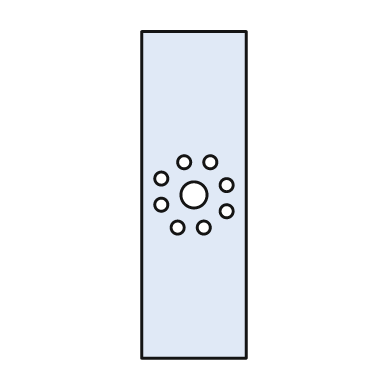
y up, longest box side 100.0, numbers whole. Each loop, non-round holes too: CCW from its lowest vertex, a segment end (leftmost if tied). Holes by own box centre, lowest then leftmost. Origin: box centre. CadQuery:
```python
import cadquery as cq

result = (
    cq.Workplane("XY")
    .moveTo(-16.0, -50.0)
    .lineTo(16.0, -50.0)
    .lineTo(16.0, 50.0)
    .lineTo(-16.0, 50.0)
    .close()
    .moveTo(-5.0, -10.0)
    .circle(2.0)
    .moveTo(3.0, -10.0)
    .circle(2.0)
    .moveTo(10.0, -5.0)
    .circle(2.0)
    .moveTo(-10.0, -3.0)
    .circle(2.0)
    .moveTo(0.0, 0.0)
    .circle(4.0)
    .moveTo(10.0, 3.0)
    .circle(2.0)
    .moveTo(-10.0, 5.0)
    .circle(2.0)
    .moveTo(-3.0, 10.0)
    .circle(2.0)
    .moveTo(5.0, 10.0)
    .circle(2.0)
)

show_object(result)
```